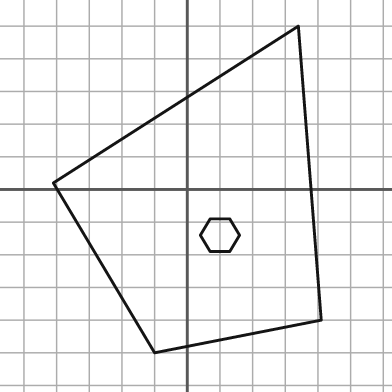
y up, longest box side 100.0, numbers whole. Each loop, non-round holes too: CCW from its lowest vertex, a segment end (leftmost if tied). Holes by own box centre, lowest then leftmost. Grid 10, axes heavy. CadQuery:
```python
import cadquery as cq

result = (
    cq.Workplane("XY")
    .moveTo(-10.0, -50.0)
    .lineTo(41.0, -40.0)
    .lineTo(34.0, 50.0)
    .lineTo(-41.0, 2.0)
    .close()
    .moveTo(7.0, -19.0)
    .lineTo(13.0, -19.0)
    .lineTo(16.0, -14.0)
    .lineTo(13.0, -9.0)
    .lineTo(7.0, -9.0)
    .lineTo(4.0, -14.0)
    .close()
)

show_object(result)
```